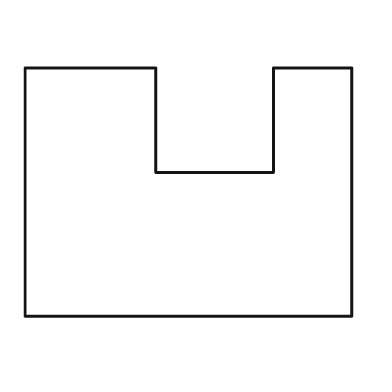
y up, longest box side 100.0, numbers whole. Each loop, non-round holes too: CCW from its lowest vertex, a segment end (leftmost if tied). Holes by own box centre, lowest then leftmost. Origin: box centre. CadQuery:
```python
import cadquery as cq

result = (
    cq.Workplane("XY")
    .moveTo(-50.0, -38.0)
    .lineTo(50.0, -38.0)
    .lineTo(50.0, 38.0)
    .lineTo(26.0, 38.0)
    .lineTo(26.0, 6.0)
    .lineTo(-10.0, 6.0)
    .lineTo(-10.0, 38.0)
    .lineTo(-50.0, 38.0)
    .close()
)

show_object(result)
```